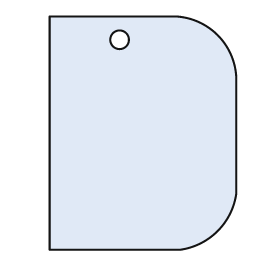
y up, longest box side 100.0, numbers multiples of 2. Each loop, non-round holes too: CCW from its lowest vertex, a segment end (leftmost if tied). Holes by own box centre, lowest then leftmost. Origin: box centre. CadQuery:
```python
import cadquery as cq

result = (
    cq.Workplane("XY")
    .moveTo(-40.0, -50.0)
    .lineTo(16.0, -50.0)
    .threePointArc((32.0, -42.0), (40.0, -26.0))
    .lineTo(40.0, 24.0)
    .threePointArc((32.0, 42.0), (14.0, 50.0))
    .lineTo(-40.0, 50.0)
    .close()
    .moveTo(-10.0, 40.0)
    .circle(4.0)
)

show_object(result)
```